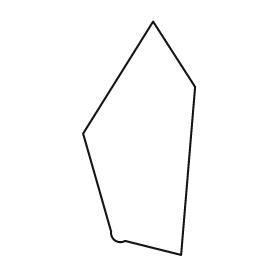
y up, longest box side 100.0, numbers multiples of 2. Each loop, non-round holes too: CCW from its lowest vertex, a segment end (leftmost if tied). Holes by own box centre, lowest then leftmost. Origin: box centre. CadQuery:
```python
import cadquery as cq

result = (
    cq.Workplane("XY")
    .moveTo(18.0, -50.0)
    .lineTo(24.0, 22.0)
    .lineTo(6.0, 50.0)
    .lineTo(-24.0, 2.0)
    .lineTo(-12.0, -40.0)
    .threePointArc((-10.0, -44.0), (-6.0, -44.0))
    .close()
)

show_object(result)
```